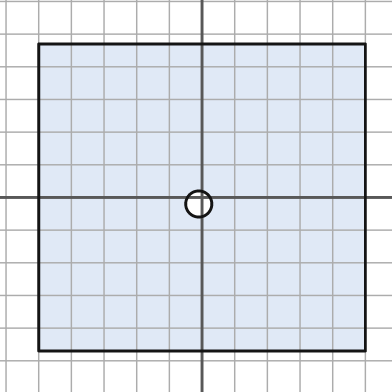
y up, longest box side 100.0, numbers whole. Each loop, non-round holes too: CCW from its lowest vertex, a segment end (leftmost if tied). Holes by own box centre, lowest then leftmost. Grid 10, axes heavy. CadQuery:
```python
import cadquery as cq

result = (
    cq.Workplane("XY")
    .moveTo(-50.0, -47.0)
    .lineTo(50.0, -47.0)
    .lineTo(50.0, 47.0)
    .lineTo(-50.0, 47.0)
    .close()
    .moveTo(-1.0, -2.0)
    .circle(4.0)
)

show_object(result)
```